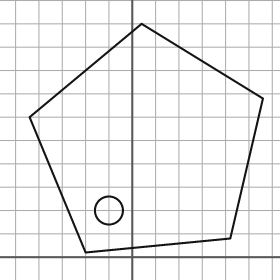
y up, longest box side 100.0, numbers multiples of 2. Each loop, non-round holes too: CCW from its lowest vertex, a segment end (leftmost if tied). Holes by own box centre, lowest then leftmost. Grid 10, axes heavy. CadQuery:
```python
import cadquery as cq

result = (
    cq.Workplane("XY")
    .moveTo(-20.0, 2.0)
    .lineTo(42.0, 8.0)
    .lineTo(56.0, 68.0)
    .lineTo(4.0, 100.0)
    .lineTo(-44.0, 60.0)
    .close()
    .moveTo(-10.0, 20.0)
    .circle(6.0)
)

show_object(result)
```